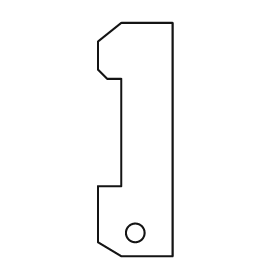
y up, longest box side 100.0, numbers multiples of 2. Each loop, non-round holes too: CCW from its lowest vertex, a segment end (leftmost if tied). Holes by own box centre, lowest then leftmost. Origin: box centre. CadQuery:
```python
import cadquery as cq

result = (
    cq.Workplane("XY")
    .moveTo(-6.0, -50.0)
    .lineTo(16.0, -50.0)
    .lineTo(16.0, 50.0)
    .lineTo(-6.0, 50.0)
    .lineTo(-16.0, 42.0)
    .lineTo(-16.0, 30.0)
    .lineTo(-12.0, 26.0)
    .lineTo(-6.0, 26.0)
    .lineTo(-6.0, -20.0)
    .lineTo(-16.0, -20.0)
    .lineTo(-16.0, -44.0)
    .close()
    .moveTo(0.0, -40.0)
    .circle(4.0)
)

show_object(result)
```